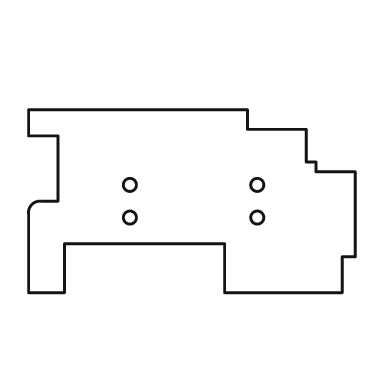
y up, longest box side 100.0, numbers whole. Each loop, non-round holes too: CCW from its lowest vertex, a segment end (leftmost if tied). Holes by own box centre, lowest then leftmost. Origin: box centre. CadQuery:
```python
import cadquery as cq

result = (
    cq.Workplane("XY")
    .moveTo(-50.0, -28.0)
    .lineTo(-39.0, -28.0)
    .lineTo(-39.0, -13.0)
    .lineTo(10.0, -13.0)
    .lineTo(10.0, -28.0)
    .lineTo(46.0, -28.0)
    .lineTo(46.0, -17.0)
    .lineTo(50.0, -17.0)
    .lineTo(50.0, 9.0)
    .lineTo(38.0, 9.0)
    .lineTo(38.0, 12.0)
    .lineTo(35.0, 12.0)
    .lineTo(35.0, 22.0)
    .lineTo(17.0, 22.0)
    .lineTo(17.0, 28.0)
    .lineTo(-50.0, 28.0)
    .lineTo(-50.0, 20.0)
    .lineTo(-41.0, 20.0)
    .lineTo(-41.0, 0.0)
    .lineTo(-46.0, 0.0)
    .threePointArc((-49.0, -1.0), (-50.0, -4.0))
    .close()
    .moveTo(-19.0, -5.0)
    .circle(2.0)
    .moveTo(20.0, -5.0)
    .circle(2.0)
    .moveTo(-19.0, 5.0)
    .circle(2.0)
    .moveTo(20.0, 5.0)
    .circle(2.0)
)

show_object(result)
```